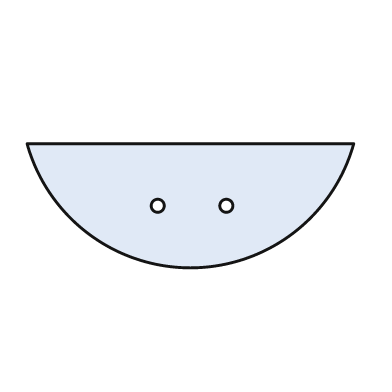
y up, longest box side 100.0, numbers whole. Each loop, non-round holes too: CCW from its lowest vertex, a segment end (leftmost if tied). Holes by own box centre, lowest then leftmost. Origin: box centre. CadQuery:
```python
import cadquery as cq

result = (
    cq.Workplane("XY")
    .moveTo(-50.0, 19.0)
    .threePointArc((0.0, -19.0), (50.0, 19.0))
    .close()
    .moveTo(-10.0, 0.0)
    .circle(2.0)
    .moveTo(11.0, 0.0)
    .circle(2.0)
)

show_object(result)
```